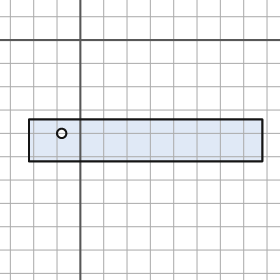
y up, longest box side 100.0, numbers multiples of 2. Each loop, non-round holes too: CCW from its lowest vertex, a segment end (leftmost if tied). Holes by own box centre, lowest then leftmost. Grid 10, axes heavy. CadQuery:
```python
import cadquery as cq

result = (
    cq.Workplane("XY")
    .moveTo(-22.0, -52.0)
    .lineTo(78.0, -52.0)
    .lineTo(78.0, -34.0)
    .lineTo(-22.0, -34.0)
    .close()
    .moveTo(-8.0, -40.0)
    .circle(2.0)
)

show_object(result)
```